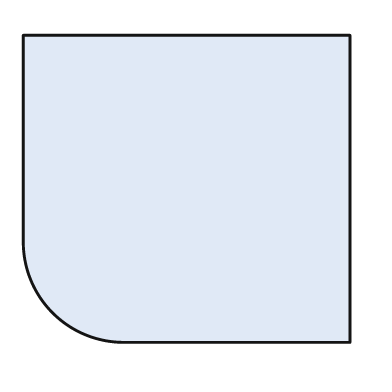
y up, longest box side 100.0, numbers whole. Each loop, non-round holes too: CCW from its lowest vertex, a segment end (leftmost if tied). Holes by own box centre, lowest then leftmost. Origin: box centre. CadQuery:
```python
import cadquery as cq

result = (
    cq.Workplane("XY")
    .moveTo(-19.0, -47.0)
    .lineTo(50.0, -47.0)
    .lineTo(50.0, 47.0)
    .lineTo(-50.0, 47.0)
    .lineTo(-50.0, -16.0)
    .threePointArc((-41.0, -38.0), (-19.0, -47.0))
    .close()
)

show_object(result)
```